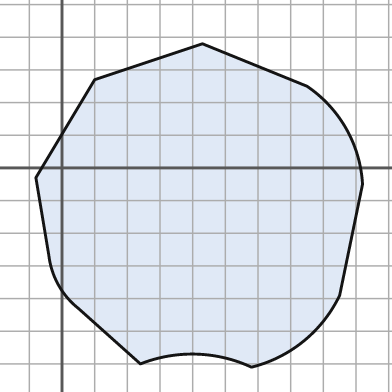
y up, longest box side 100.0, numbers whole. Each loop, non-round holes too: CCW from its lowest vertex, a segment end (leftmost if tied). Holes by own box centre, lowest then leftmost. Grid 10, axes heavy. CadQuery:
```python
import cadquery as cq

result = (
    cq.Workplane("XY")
    .moveTo(58.0, -61.0)
    .threePointArc((74.0, -53.0), (85.0, -39.0))
    .lineTo(92.0, -5.0)
    .threePointArc((87.0, 12.0), (75.0, 25.0))
    .lineTo(43.0, 38.0)
    .lineTo(10.0, 27.0)
    .lineTo(-8.0, -3.0)
    .lineTo(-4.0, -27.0)
    .threePointArc((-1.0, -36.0), (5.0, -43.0))
    .lineTo(24.0, -60.0)
    .threePointArc((41.0, -57.0), (58.0, -61.0))
    .close()
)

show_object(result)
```